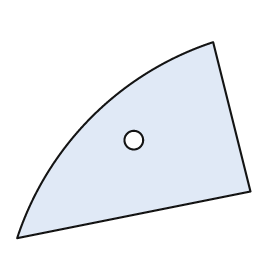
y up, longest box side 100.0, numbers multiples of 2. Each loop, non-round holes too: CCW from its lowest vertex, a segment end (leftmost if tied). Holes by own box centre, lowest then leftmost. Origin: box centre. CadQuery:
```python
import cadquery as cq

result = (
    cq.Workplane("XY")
    .moveTo(-50.0, -42.0)
    .lineTo(50.0, -22.0)
    .lineTo(34.0, 42.0)
    .threePointArc((-18.0, 10.0), (-50.0, -42.0))
    .close()
    .moveTo(0.0, 0.0)
    .circle(4.0)
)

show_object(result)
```